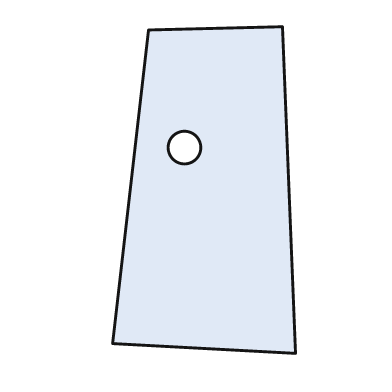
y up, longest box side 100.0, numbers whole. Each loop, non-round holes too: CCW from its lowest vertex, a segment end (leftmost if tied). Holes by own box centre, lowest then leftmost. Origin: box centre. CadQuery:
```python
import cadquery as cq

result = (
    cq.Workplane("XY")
    .moveTo(28.0, -50.0)
    .lineTo(24.0, 50.0)
    .lineTo(-17.0, 49.0)
    .lineTo(-28.0, -47.0)
    .close()
    .moveTo(-6.0, 13.0)
    .circle(5.0)
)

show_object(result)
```